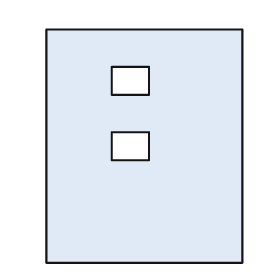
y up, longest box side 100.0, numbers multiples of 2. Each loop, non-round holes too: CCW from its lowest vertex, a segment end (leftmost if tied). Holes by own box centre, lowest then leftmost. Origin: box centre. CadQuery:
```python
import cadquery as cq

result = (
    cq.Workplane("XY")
    .moveTo(-42.0, -50.0)
    .lineTo(42.0, -50.0)
    .lineTo(42.0, 50.0)
    .lineTo(-42.0, 50.0)
    .close()
    .moveTo(-14.0, -6.0)
    .lineTo(2.0, -6.0)
    .lineTo(2.0, 6.0)
    .lineTo(-14.0, 6.0)
    .close()
    .moveTo(-14.0, 22.0)
    .lineTo(2.0, 22.0)
    .lineTo(2.0, 34.0)
    .lineTo(-14.0, 34.0)
    .close()
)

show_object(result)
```